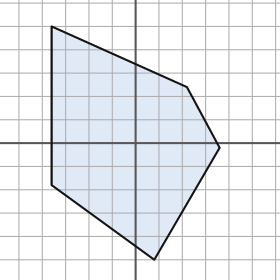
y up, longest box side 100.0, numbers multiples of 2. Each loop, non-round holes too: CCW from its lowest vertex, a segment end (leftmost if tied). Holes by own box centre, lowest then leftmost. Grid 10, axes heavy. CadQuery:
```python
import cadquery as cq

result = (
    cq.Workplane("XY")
    .moveTo(8.0, -50.0)
    .lineTo(36.0, -2.0)
    .lineTo(22.0, 24.0)
    .lineTo(-36.0, 50.0)
    .lineTo(-36.0, -18.0)
    .close()
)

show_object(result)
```